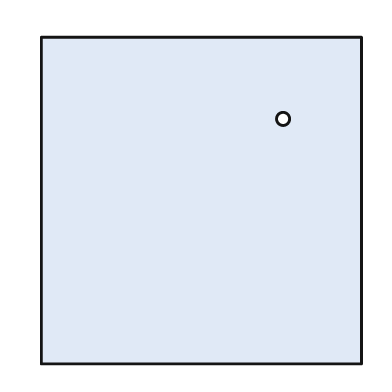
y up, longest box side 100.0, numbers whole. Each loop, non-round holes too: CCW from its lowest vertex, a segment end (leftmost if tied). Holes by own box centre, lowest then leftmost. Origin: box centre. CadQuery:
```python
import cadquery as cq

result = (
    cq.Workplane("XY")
    .moveTo(-49.0, -50.0)
    .lineTo(49.0, -50.0)
    .lineTo(49.0, 50.0)
    .lineTo(-49.0, 50.0)
    .close()
    .moveTo(25.0, 25.0)
    .circle(2.0)
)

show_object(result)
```